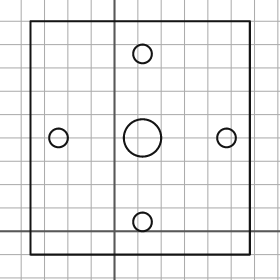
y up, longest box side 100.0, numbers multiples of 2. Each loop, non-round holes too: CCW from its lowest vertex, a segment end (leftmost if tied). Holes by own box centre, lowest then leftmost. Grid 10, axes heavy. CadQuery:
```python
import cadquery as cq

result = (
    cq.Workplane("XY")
    .moveTo(-36.0, -10.0)
    .lineTo(58.0, -10.0)
    .lineTo(58.0, 90.0)
    .lineTo(-36.0, 90.0)
    .close()
    .moveTo(12.0, 4.0)
    .circle(4.0)
    .moveTo(-24.0, 40.0)
    .circle(4.0)
    .moveTo(12.0, 40.0)
    .circle(8.0)
    .moveTo(48.0, 40.0)
    .circle(4.0)
    .moveTo(12.0, 76.0)
    .circle(4.0)
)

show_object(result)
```